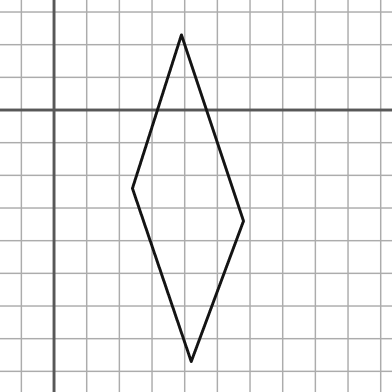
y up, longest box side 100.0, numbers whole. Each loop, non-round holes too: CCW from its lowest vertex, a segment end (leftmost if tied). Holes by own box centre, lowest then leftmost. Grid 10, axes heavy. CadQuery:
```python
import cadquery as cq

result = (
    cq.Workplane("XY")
    .moveTo(42.0, -77.0)
    .lineTo(58.0, -34.0)
    .lineTo(39.0, 23.0)
    .lineTo(24.0, -24.0)
    .close()
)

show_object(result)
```